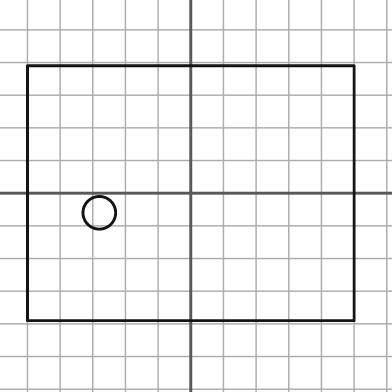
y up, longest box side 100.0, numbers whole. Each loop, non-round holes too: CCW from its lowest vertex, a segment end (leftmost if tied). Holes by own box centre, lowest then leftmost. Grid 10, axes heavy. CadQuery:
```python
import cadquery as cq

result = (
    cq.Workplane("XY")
    .moveTo(-50.0, -39.0)
    .lineTo(50.0, -39.0)
    .lineTo(50.0, 39.0)
    .lineTo(-50.0, 39.0)
    .close()
    .moveTo(-28.0, -6.0)
    .circle(5.0)
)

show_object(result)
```